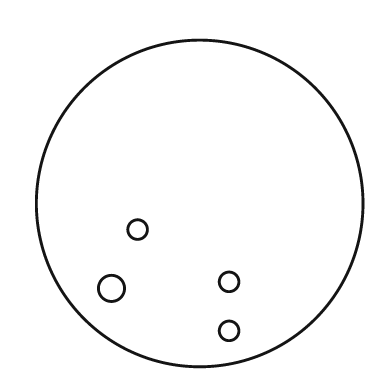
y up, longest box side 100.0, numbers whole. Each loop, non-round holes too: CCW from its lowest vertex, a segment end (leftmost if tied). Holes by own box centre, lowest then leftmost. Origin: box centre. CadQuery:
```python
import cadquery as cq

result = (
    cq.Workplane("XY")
    .moveTo(0.0, 0.0)
    .circle(50.0)
    .moveTo(9.0, -39.0)
    .circle(3.0)
    .moveTo(-27.0, -26.0)
    .circle(4.0)
    .moveTo(9.0, -24.0)
    .circle(3.0)
    .moveTo(-19.0, -8.0)
    .circle(3.0)
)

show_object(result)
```